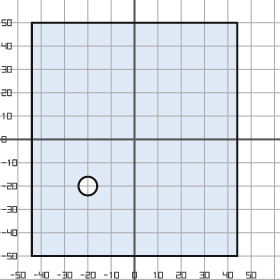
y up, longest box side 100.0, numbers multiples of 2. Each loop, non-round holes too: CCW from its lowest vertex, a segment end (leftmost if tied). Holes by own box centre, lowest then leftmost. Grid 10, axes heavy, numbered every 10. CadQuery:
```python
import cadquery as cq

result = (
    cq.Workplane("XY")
    .moveTo(-44.0, -50.0)
    .lineTo(44.0, -50.0)
    .lineTo(44.0, 50.0)
    .lineTo(-44.0, 50.0)
    .close()
    .moveTo(-20.0, -20.0)
    .circle(4.0)
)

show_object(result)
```